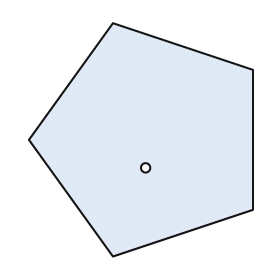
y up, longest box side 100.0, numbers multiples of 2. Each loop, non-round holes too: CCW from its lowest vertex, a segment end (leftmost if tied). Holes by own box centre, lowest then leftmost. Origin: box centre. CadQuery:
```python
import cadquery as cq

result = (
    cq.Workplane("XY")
    .moveTo(-12.0, -50.0)
    .lineTo(48.0, -30.0)
    .lineTo(48.0, 30.0)
    .lineTo(-12.0, 50.0)
    .lineTo(-48.0, 0.0)
    .close()
    .moveTo(2.0, -12.0)
    .circle(2.0)
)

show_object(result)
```